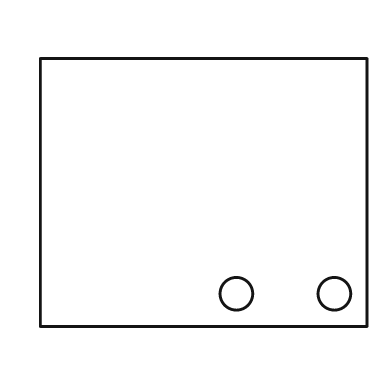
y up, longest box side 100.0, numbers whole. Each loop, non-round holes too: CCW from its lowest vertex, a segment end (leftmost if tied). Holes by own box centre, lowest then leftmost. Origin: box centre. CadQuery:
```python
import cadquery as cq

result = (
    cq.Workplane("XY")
    .moveTo(-50.0, -41.0)
    .lineTo(50.0, -41.0)
    .lineTo(50.0, 41.0)
    .lineTo(-50.0, 41.0)
    .close()
    .moveTo(10.0, -31.0)
    .circle(5.0)
    .moveTo(40.0, -31.0)
    .circle(5.0)
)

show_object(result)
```